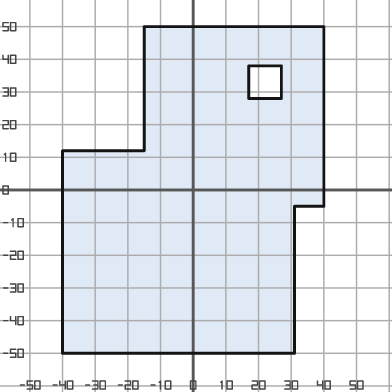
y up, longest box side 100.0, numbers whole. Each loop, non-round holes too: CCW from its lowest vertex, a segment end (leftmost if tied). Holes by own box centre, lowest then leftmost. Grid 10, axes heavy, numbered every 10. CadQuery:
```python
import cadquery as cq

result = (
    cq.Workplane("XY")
    .moveTo(-40.0, -50.0)
    .lineTo(31.0, -50.0)
    .lineTo(31.0, -5.0)
    .lineTo(40.0, -5.0)
    .lineTo(40.0, 50.0)
    .lineTo(-15.0, 50.0)
    .lineTo(-15.0, 12.0)
    .lineTo(-40.0, 12.0)
    .close()
    .moveTo(17.0, 28.0)
    .lineTo(27.0, 28.0)
    .lineTo(27.0, 38.0)
    .lineTo(17.0, 38.0)
    .close()
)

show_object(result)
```